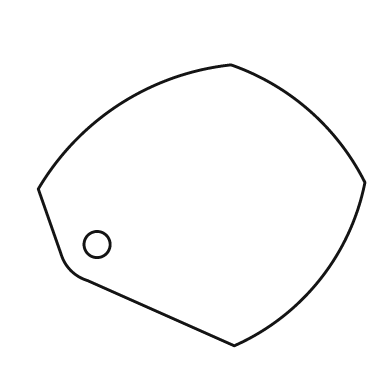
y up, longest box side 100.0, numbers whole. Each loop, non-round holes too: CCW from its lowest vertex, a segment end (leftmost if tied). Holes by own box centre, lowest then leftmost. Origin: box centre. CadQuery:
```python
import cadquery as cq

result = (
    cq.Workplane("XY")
    .moveTo(10.0, -43.0)
    .threePointArc((36.0, -23.0), (50.0, 7.0))
    .threePointArc((33.0, 29.0), (9.0, 43.0))
    .threePointArc((-25.0, 31.0), (-50.0, 5.0))
    .lineTo(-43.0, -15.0)
    .threePointArc((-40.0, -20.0), (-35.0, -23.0))
    .close()
    .moveTo(-32.0, -12.0)
    .circle(4.0)
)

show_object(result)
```